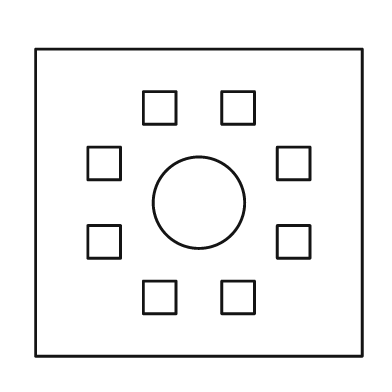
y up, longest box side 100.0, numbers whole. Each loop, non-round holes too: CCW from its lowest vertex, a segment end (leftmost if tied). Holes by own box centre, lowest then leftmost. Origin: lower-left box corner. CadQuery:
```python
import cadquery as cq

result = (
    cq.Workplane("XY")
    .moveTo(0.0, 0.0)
    .lineTo(100.0, 0.0)
    .lineTo(100.0, 94.0)
    .lineTo(0.0, 94.0)
    .close()
    .moveTo(33.0, 13.0)
    .lineTo(43.0, 13.0)
    .lineTo(43.0, 23.0)
    .lineTo(33.0, 23.0)
    .close()
    .moveTo(57.0, 13.0)
    .lineTo(67.0, 13.0)
    .lineTo(67.0, 23.0)
    .lineTo(57.0, 23.0)
    .close()
    .moveTo(16.0, 30.0)
    .lineTo(26.0, 30.0)
    .lineTo(26.0, 40.0)
    .lineTo(16.0, 40.0)
    .close()
    .moveTo(74.0, 30.0)
    .lineTo(84.0, 30.0)
    .lineTo(84.0, 40.0)
    .lineTo(74.0, 40.0)
    .close()
    .moveTo(50.0, 47.0)
    .circle(14.0)
    .moveTo(16.0, 54.0)
    .lineTo(26.0, 54.0)
    .lineTo(26.0, 64.0)
    .lineTo(16.0, 64.0)
    .close()
    .moveTo(74.0, 54.0)
    .lineTo(84.0, 54.0)
    .lineTo(84.0, 64.0)
    .lineTo(74.0, 64.0)
    .close()
    .moveTo(33.0, 71.0)
    .lineTo(43.0, 71.0)
    .lineTo(43.0, 81.0)
    .lineTo(33.0, 81.0)
    .close()
    .moveTo(57.0, 71.0)
    .lineTo(67.0, 71.0)
    .lineTo(67.0, 81.0)
    .lineTo(57.0, 81.0)
    .close()
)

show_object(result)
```